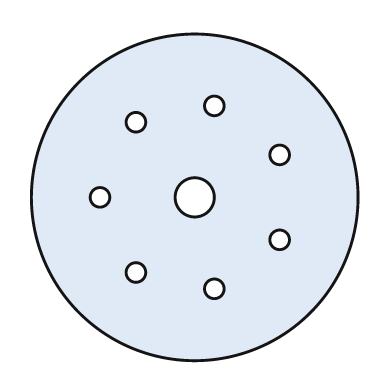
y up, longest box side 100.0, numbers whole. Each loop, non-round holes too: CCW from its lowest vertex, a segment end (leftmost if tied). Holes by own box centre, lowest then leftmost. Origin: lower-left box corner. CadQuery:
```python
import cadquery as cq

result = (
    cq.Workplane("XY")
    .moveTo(50.0, 50.0)
    .circle(50.0)
    .moveTo(56.0, 22.0)
    .circle(3.0)
    .moveTo(32.0, 27.0)
    .circle(3.0)
    .moveTo(76.0, 37.0)
    .circle(3.0)
    .moveTo(21.0, 50.0)
    .circle(3.0)
    .moveTo(50.0, 50.0)
    .circle(6.0)
    .moveTo(76.0, 63.0)
    .circle(3.0)
    .moveTo(32.0, 73.0)
    .circle(3.0)
    .moveTo(56.0, 78.0)
    .circle(3.0)
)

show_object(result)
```